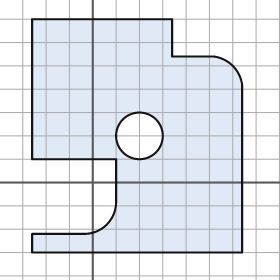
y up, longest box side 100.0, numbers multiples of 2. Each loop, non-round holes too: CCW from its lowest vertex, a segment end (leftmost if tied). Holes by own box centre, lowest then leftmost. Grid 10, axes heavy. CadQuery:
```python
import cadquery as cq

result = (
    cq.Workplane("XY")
    .moveTo(-26.0, -30.0)
    .lineTo(64.0, -30.0)
    .lineTo(64.0, 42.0)
    .threePointArc((60.0, 50.0), (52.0, 54.0))
    .lineTo(34.0, 54.0)
    .lineTo(34.0, 70.0)
    .lineTo(-26.0, 70.0)
    .lineTo(-26.0, 10.0)
    .lineTo(10.0, 10.0)
    .lineTo(10.0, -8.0)
    .threePointArc((6.0, -18.0), (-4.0, -22.0))
    .lineTo(-26.0, -22.0)
    .close()
    .moveTo(20.0, 20.0)
    .circle(10.0)
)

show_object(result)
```